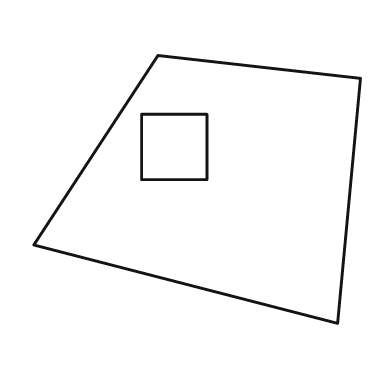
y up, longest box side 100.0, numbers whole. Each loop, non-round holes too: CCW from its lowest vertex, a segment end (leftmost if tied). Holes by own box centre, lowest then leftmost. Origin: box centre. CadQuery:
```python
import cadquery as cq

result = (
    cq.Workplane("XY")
    .moveTo(43.0, -41.0)
    .lineTo(50.0, 34.0)
    .lineTo(-12.0, 41.0)
    .lineTo(-50.0, -17.0)
    .close()
    .moveTo(-17.0, 3.0)
    .lineTo(3.0, 3.0)
    .lineTo(3.0, 23.0)
    .lineTo(-17.0, 23.0)
    .close()
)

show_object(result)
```